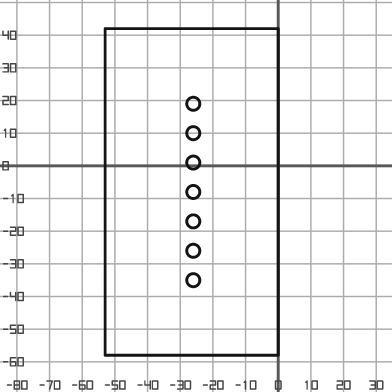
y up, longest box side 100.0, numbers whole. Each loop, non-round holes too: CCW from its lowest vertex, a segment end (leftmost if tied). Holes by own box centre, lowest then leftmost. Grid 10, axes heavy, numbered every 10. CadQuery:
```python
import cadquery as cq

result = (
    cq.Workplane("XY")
    .moveTo(-53.0, -58.0)
    .lineTo(0.0, -58.0)
    .lineTo(0.0, 42.0)
    .lineTo(-53.0, 42.0)
    .close()
    .moveTo(-26.0, -35.0)
    .circle(2.0)
    .moveTo(-26.0, -26.0)
    .circle(2.0)
    .moveTo(-26.0, -17.0)
    .circle(2.0)
    .moveTo(-26.0, -8.0)
    .circle(2.0)
    .moveTo(-26.0, 1.0)
    .circle(2.0)
    .moveTo(-26.0, 10.0)
    .circle(2.0)
    .moveTo(-26.0, 19.0)
    .circle(2.0)
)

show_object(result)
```